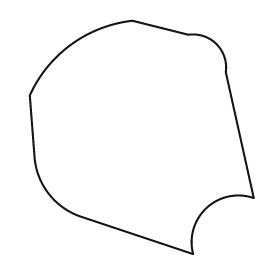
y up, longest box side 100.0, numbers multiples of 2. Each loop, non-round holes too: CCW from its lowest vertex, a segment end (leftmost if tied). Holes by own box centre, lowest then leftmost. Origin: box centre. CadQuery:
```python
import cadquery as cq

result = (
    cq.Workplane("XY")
    .moveTo(22.0, -50.0)
    .threePointArc((28.0, -30.0), (48.0, -26.0))
    .lineTo(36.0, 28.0)
    .threePointArc((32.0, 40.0), (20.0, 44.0))
    .lineTo(-4.0, 50.0)
    .threePointArc((-30.0, 40.0), (-48.0, 18.0))
    .lineTo(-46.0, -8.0)
    .threePointArc((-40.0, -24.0), (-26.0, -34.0))
    .close()
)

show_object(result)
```